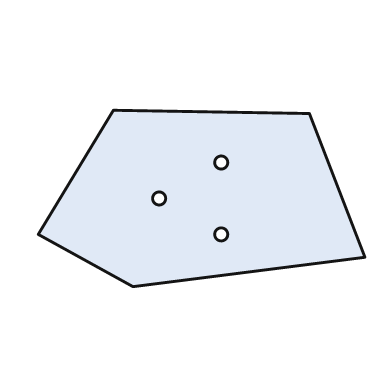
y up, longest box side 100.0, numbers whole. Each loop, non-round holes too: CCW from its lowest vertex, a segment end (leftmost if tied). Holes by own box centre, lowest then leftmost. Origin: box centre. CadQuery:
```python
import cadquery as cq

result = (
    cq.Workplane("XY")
    .moveTo(-21.0, -27.0)
    .lineTo(50.0, -18.0)
    .lineTo(33.0, 26.0)
    .lineTo(-27.0, 27.0)
    .lineTo(-50.0, -11.0)
    .close()
    .moveTo(6.0, -11.0)
    .circle(2.0)
    .moveTo(-13.0, 0.0)
    .circle(2.0)
    .moveTo(6.0, 11.0)
    .circle(2.0)
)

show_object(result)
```